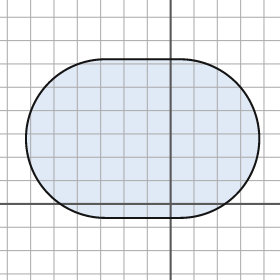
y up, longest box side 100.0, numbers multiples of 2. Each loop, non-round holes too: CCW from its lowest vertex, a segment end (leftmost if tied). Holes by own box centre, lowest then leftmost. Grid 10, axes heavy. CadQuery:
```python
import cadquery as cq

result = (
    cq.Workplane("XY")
    .moveTo(-28.0, -6.0)
    .lineTo(4.0, -6.0)
    .threePointArc((38.0, 28.0), (4.0, 62.0))
    .lineTo(-28.0, 62.0)
    .threePointArc((-62.0, 28.0), (-28.0, -6.0))
    .close()
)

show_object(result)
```